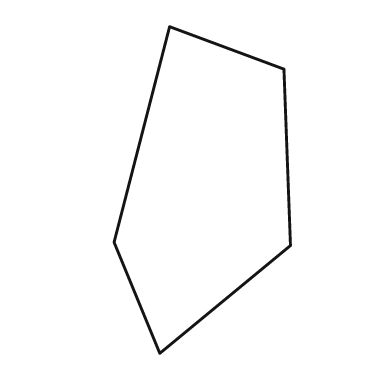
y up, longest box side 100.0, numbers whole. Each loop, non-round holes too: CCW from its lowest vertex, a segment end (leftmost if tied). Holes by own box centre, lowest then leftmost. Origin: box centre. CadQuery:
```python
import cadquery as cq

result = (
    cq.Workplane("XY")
    .moveTo(-13.0, -50.0)
    .lineTo(27.0, -17.0)
    .lineTo(25.0, 37.0)
    .lineTo(-10.0, 50.0)
    .lineTo(-27.0, -16.0)
    .close()
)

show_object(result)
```